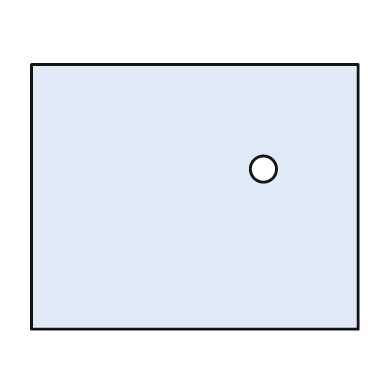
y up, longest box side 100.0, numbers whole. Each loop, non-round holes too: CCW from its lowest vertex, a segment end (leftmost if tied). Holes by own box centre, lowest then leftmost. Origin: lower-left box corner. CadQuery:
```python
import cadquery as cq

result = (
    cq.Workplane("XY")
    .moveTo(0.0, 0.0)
    .lineTo(100.0, 0.0)
    .lineTo(100.0, 81.0)
    .lineTo(0.0, 81.0)
    .close()
    .moveTo(71.0, 49.0)
    .circle(4.0)
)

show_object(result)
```